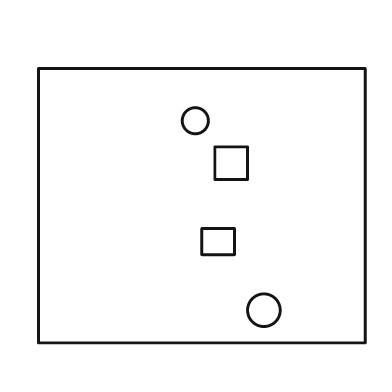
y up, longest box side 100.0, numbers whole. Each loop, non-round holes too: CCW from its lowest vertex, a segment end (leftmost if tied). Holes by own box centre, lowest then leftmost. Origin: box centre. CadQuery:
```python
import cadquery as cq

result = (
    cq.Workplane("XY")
    .moveTo(-50.0, -42.0)
    .lineTo(50.0, -42.0)
    .lineTo(50.0, 42.0)
    .lineTo(-50.0, 42.0)
    .close()
    .moveTo(19.0, -32.0)
    .circle(5.0)
    .moveTo(0.0, -15.0)
    .lineTo(10.0, -15.0)
    .lineTo(10.0, -7.0)
    .lineTo(0.0, -7.0)
    .close()
    .moveTo(4.0, 8.0)
    .lineTo(14.0, 8.0)
    .lineTo(14.0, 18.0)
    .lineTo(4.0, 18.0)
    .close()
    .moveTo(-2.0, 26.0)
    .circle(4.0)
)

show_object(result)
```